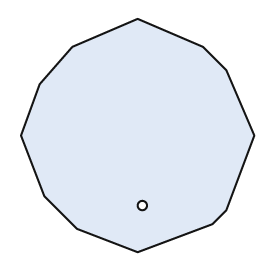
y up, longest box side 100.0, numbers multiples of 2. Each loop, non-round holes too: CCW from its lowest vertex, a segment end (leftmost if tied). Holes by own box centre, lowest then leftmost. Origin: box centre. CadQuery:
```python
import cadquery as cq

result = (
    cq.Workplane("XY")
    .moveTo(0.0, -50.0)
    .lineTo(32.0, -38.0)
    .lineTo(38.0, -32.0)
    .lineTo(50.0, 0.0)
    .lineTo(38.0, 28.0)
    .lineTo(28.0, 38.0)
    .lineTo(0.0, 50.0)
    .lineTo(-28.0, 38.0)
    .lineTo(-42.0, 22.0)
    .lineTo(-50.0, 0.0)
    .lineTo(-40.0, -26.0)
    .lineTo(-26.0, -40.0)
    .close()
    .moveTo(2.0, -30.0)
    .circle(2.0)
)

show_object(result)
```